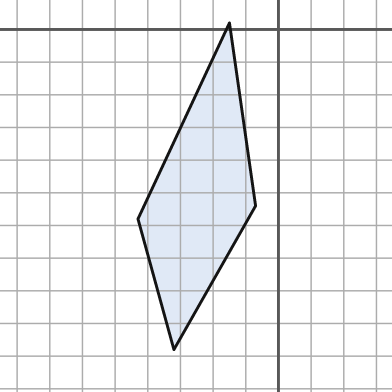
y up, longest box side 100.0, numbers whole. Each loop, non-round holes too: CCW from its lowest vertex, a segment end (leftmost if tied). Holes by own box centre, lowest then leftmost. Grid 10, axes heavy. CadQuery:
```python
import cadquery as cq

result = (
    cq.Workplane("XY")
    .moveTo(-32.0, -98.0)
    .lineTo(-7.0, -54.0)
    .lineTo(-15.0, 2.0)
    .lineTo(-43.0, -58.0)
    .close()
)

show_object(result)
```